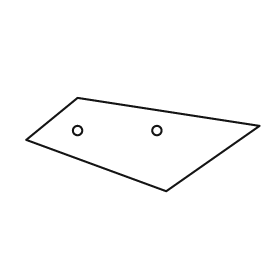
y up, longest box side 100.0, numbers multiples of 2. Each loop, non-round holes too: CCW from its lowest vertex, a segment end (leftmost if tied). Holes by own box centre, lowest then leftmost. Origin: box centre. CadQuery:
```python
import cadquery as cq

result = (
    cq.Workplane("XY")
    .moveTo(10.0, -20.0)
    .lineTo(50.0, 8.0)
    .lineTo(-28.0, 20.0)
    .lineTo(-50.0, 2.0)
    .close()
    .moveTo(-28.0, 6.0)
    .circle(2.0)
    .moveTo(6.0, 6.0)
    .circle(2.0)
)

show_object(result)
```